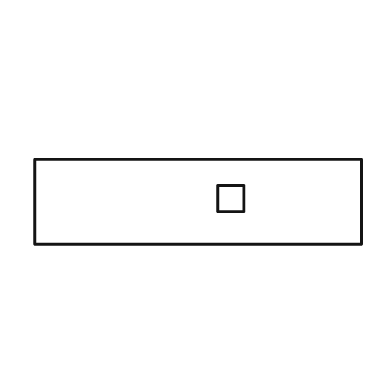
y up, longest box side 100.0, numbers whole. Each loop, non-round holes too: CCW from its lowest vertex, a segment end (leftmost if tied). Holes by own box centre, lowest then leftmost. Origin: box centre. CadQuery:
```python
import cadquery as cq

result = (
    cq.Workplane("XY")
    .moveTo(-50.0, -13.0)
    .lineTo(50.0, -13.0)
    .lineTo(50.0, 13.0)
    .lineTo(-50.0, 13.0)
    .close()
    .moveTo(6.0, -3.0)
    .lineTo(14.0, -3.0)
    .lineTo(14.0, 5.0)
    .lineTo(6.0, 5.0)
    .close()
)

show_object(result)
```